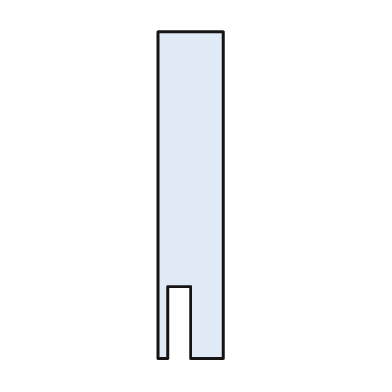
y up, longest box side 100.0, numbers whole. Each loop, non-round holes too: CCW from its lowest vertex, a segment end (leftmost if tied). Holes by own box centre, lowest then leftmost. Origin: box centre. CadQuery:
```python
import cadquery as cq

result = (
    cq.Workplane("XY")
    .moveTo(-10.0, -50.0)
    .lineTo(-7.0, -50.0)
    .lineTo(-7.0, -28.0)
    .lineTo(0.0, -28.0)
    .lineTo(0.0, -50.0)
    .lineTo(10.0, -50.0)
    .lineTo(10.0, 50.0)
    .lineTo(-10.0, 50.0)
    .close()
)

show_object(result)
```